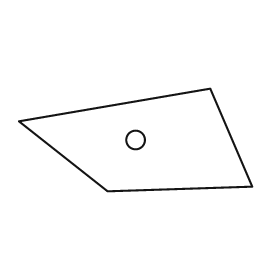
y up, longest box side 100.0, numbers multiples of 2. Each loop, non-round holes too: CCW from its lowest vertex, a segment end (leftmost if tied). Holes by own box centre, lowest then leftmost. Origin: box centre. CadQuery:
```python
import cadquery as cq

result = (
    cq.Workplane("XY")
    .moveTo(-12.0, -22.0)
    .lineTo(50.0, -20.0)
    .lineTo(32.0, 22.0)
    .lineTo(-50.0, 8.0)
    .close()
    .moveTo(0.0, 0.0)
    .circle(4.0)
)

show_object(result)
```